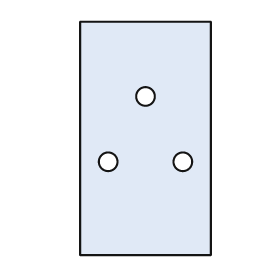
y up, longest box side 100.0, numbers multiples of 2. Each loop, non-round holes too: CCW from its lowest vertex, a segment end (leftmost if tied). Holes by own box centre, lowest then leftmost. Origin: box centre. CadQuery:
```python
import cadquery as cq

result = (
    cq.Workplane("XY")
    .moveTo(-28.0, -50.0)
    .lineTo(28.0, -50.0)
    .lineTo(28.0, 50.0)
    .lineTo(-28.0, 50.0)
    .close()
    .moveTo(-16.0, -10.0)
    .circle(4.0)
    .moveTo(16.0, -10.0)
    .circle(4.0)
    .moveTo(0.0, 18.0)
    .circle(4.0)
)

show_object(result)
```